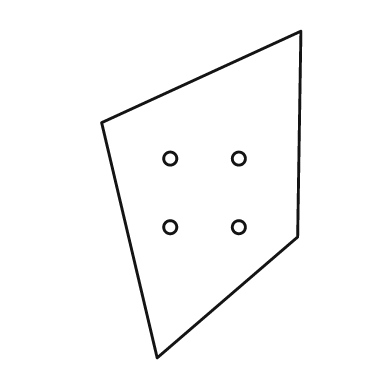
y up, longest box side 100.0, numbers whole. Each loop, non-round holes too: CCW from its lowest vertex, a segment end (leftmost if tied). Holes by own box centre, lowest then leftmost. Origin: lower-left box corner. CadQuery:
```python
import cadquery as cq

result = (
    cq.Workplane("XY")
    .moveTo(17.0, 0.0)
    .lineTo(60.0, 37.0)
    .lineTo(61.0, 100.0)
    .lineTo(0.0, 72.0)
    .close()
    .moveTo(21.0, 40.0)
    .circle(2.0)
    .moveTo(42.0, 40.0)
    .circle(2.0)
    .moveTo(21.0, 61.0)
    .circle(2.0)
    .moveTo(42.0, 61.0)
    .circle(2.0)
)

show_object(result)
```